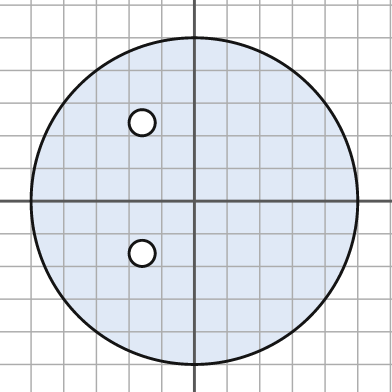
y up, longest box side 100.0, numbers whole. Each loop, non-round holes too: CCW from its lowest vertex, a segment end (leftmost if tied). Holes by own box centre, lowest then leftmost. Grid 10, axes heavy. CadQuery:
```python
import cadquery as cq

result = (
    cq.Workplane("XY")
    .moveTo(0.0, 0.0)
    .circle(50.0)
    .moveTo(-16.0, -16.0)
    .circle(4.0)
    .moveTo(-16.0, 24.0)
    .circle(4.0)
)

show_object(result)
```